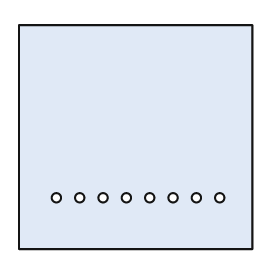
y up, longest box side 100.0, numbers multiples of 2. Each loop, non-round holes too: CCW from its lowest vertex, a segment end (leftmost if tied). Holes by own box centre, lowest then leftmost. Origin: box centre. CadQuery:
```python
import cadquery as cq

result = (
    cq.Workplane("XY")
    .moveTo(-50.0, -48.0)
    .lineTo(50.0, -48.0)
    .lineTo(50.0, 48.0)
    .lineTo(-50.0, 48.0)
    .close()
    .moveTo(-34.0, -26.0)
    .circle(2.0)
    .moveTo(-24.0, -26.0)
    .circle(2.0)
    .moveTo(-14.0, -26.0)
    .circle(2.0)
    .moveTo(-4.0, -26.0)
    .circle(2.0)
    .moveTo(6.0, -26.0)
    .circle(2.0)
    .moveTo(16.0, -26.0)
    .circle(2.0)
    .moveTo(26.0, -26.0)
    .circle(2.0)
    .moveTo(36.0, -26.0)
    .circle(2.0)
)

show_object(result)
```